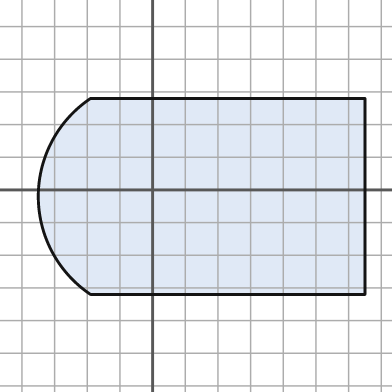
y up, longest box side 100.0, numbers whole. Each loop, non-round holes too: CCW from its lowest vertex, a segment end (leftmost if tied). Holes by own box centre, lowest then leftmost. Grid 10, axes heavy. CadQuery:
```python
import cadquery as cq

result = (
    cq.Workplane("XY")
    .moveTo(-19.0, -32.0)
    .lineTo(65.0, -32.0)
    .lineTo(65.0, 28.0)
    .lineTo(-19.0, 28.0)
    .threePointArc((-35.0, -2.0), (-19.0, -32.0))
    .close()
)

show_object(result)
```